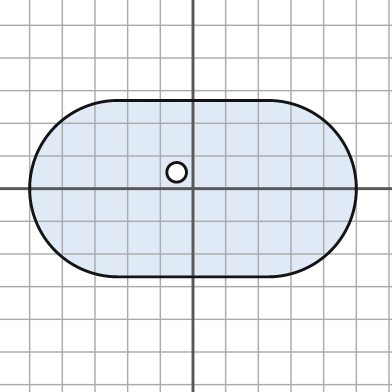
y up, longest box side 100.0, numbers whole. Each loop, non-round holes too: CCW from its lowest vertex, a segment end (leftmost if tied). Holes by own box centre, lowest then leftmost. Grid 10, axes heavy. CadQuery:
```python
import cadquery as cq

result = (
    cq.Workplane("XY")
    .moveTo(-23.0, -27.0)
    .lineTo(23.0, -27.0)
    .threePointArc((50.0, 0.0), (23.0, 27.0))
    .lineTo(-23.0, 27.0)
    .threePointArc((-50.0, 0.0), (-23.0, -27.0))
    .close()
    .moveTo(-5.0, 5.0)
    .circle(3.0)
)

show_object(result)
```